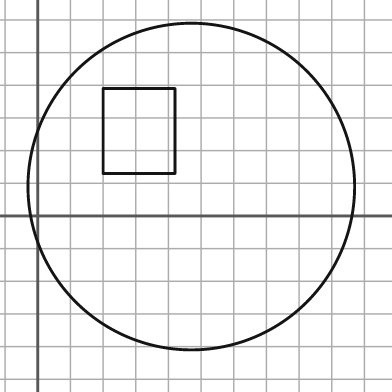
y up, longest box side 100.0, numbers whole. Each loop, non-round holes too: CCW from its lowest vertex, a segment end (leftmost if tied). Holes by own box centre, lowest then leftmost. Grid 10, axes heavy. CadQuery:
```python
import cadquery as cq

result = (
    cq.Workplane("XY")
    .moveTo(47.0, 9.0)
    .circle(50.0)
    .moveTo(20.0, 13.0)
    .lineTo(42.0, 13.0)
    .lineTo(42.0, 39.0)
    .lineTo(20.0, 39.0)
    .close()
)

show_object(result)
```